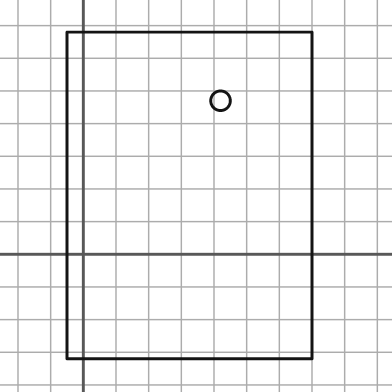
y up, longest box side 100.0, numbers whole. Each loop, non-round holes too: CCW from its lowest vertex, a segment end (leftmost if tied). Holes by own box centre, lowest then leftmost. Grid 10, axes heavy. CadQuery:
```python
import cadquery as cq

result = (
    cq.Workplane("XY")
    .moveTo(-5.0, -32.0)
    .lineTo(70.0, -32.0)
    .lineTo(70.0, 68.0)
    .lineTo(-5.0, 68.0)
    .close()
    .moveTo(42.0, 47.0)
    .circle(3.0)
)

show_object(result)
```